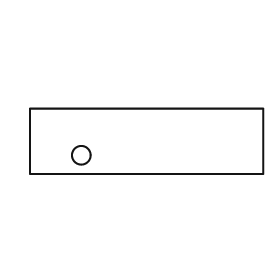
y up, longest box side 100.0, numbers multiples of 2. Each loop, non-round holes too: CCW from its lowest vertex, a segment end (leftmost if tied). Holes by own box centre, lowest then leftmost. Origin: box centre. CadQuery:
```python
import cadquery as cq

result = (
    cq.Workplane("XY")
    .moveTo(-50.0, -14.0)
    .lineTo(50.0, -14.0)
    .lineTo(50.0, 14.0)
    .lineTo(-50.0, 14.0)
    .close()
    .moveTo(-28.0, -6.0)
    .circle(4.0)
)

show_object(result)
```